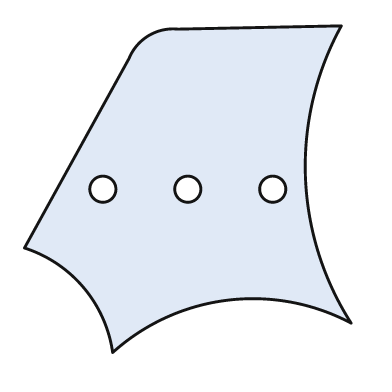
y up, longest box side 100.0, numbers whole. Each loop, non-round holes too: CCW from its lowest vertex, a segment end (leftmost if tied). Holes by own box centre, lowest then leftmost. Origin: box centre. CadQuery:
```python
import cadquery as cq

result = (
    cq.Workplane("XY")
    .moveTo(-23.0, -50.0)
    .threePointArc((12.0, -34.0), (50.0, -41.0))
    .threePointArc((36.0, 4.0), (47.0, 50.0))
    .lineTo(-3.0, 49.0)
    .threePointArc((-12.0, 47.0), (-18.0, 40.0))
    .lineTo(-50.0, -18.0)
    .threePointArc((-32.0, -30.0), (-23.0, -50.0))
    .close()
    .moveTo(-26.0, 0.0)
    .circle(4.0)
    .moveTo(0.0, 0.0)
    .circle(4.0)
    .moveTo(26.0, 0.0)
    .circle(4.0)
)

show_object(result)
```